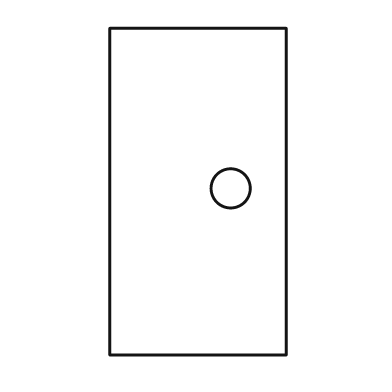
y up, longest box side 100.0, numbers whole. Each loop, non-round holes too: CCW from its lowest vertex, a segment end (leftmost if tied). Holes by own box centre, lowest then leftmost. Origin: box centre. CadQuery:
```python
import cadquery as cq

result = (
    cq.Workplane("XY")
    .moveTo(-27.0, -50.0)
    .lineTo(27.0, -50.0)
    .lineTo(27.0, 50.0)
    .lineTo(-27.0, 50.0)
    .close()
    .moveTo(10.0, 1.0)
    .circle(6.0)
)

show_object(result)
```